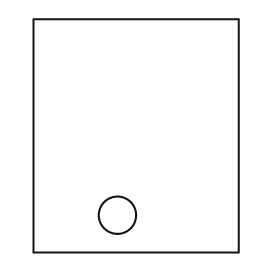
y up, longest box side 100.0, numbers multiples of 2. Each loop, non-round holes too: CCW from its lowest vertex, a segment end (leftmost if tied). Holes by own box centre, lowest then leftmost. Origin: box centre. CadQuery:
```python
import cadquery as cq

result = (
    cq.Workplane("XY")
    .moveTo(-44.0, -50.0)
    .lineTo(44.0, -50.0)
    .lineTo(44.0, 50.0)
    .lineTo(-44.0, 50.0)
    .close()
    .moveTo(-8.0, -34.0)
    .circle(8.0)
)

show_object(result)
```